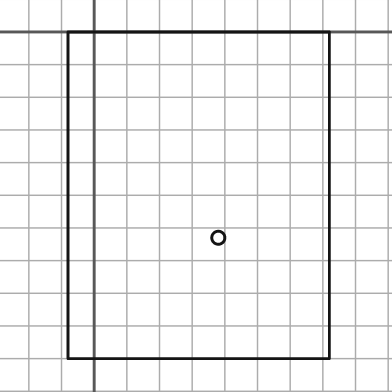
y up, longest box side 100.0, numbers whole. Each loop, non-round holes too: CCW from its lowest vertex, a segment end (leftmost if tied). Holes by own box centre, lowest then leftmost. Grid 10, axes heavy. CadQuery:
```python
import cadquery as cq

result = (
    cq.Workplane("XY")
    .moveTo(-8.0, -100.0)
    .lineTo(72.0, -100.0)
    .lineTo(72.0, 0.0)
    .lineTo(-8.0, 0.0)
    .close()
    .moveTo(38.0, -63.0)
    .circle(2.0)
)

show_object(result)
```